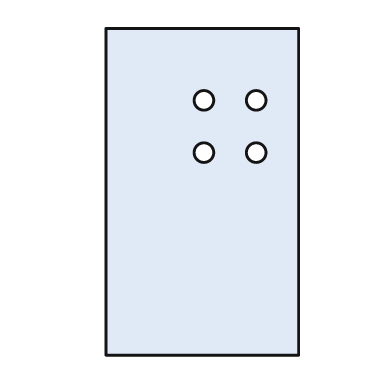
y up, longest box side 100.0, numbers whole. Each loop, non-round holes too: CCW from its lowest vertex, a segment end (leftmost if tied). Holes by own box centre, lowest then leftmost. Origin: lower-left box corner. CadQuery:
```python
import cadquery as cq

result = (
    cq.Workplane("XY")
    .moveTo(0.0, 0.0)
    .lineTo(59.0, 0.0)
    .lineTo(59.0, 100.0)
    .lineTo(0.0, 100.0)
    .close()
    .moveTo(30.0, 62.0)
    .circle(3.0)
    .moveTo(46.0, 62.0)
    .circle(3.0)
    .moveTo(30.0, 78.0)
    .circle(3.0)
    .moveTo(46.0, 78.0)
    .circle(3.0)
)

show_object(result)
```